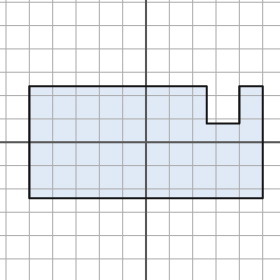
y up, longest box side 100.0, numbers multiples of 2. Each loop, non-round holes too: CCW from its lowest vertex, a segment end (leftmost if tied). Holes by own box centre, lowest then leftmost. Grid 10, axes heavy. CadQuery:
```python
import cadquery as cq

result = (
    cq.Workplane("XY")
    .moveTo(-50.0, -24.0)
    .lineTo(50.0, -24.0)
    .lineTo(50.0, 24.0)
    .lineTo(40.0, 24.0)
    .lineTo(40.0, 8.0)
    .lineTo(26.0, 8.0)
    .lineTo(26.0, 24.0)
    .lineTo(-50.0, 24.0)
    .close()
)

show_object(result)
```